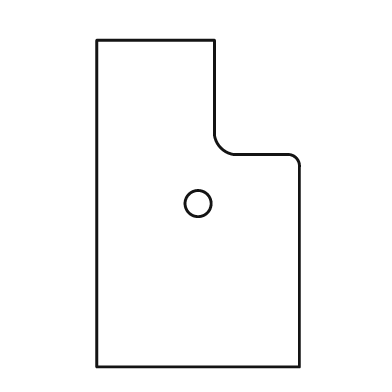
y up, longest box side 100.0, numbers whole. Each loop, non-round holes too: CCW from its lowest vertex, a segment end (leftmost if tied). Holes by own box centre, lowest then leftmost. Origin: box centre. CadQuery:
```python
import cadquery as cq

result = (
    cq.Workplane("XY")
    .moveTo(-31.0, -50.0)
    .lineTo(31.0, -50.0)
    .lineTo(31.0, 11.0)
    .threePointArc((30.0, 14.0), (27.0, 15.0))
    .lineTo(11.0, 15.0)
    .threePointArc((7.0, 17.0), (5.0, 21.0))
    .lineTo(5.0, 50.0)
    .lineTo(-31.0, 50.0)
    .close()
    .moveTo(0.0, 0.0)
    .circle(4.0)
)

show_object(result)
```